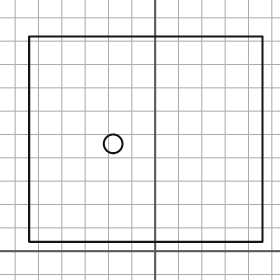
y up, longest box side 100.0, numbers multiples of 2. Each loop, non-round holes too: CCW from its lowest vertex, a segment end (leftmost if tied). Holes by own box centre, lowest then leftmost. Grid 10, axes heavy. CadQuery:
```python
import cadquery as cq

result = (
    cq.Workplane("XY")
    .moveTo(-54.0, 4.0)
    .lineTo(46.0, 4.0)
    .lineTo(46.0, 92.0)
    .lineTo(-54.0, 92.0)
    .close()
    .moveTo(-18.0, 46.0)
    .circle(4.0)
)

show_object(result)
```